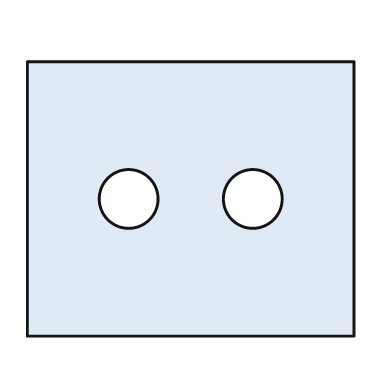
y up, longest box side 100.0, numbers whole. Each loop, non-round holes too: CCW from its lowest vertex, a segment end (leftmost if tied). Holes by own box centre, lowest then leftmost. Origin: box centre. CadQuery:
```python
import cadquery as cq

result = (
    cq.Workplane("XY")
    .moveTo(-50.0, -42.0)
    .lineTo(50.0, -42.0)
    .lineTo(50.0, 42.0)
    .lineTo(-50.0, 42.0)
    .close()
    .moveTo(-19.0, 0.0)
    .circle(9.0)
    .moveTo(19.0, 0.0)
    .circle(9.0)
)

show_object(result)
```